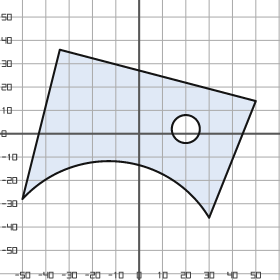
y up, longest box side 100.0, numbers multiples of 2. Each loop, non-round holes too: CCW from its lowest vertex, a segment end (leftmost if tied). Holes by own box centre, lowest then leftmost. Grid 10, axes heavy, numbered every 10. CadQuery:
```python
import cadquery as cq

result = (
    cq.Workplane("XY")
    .moveTo(30.0, -36.0)
    .lineTo(50.0, 14.0)
    .lineTo(-34.0, 36.0)
    .lineTo(-50.0, -28.0)
    .threePointArc((-8.0, -12.0), (30.0, -36.0))
    .close()
    .moveTo(20.0, 2.0)
    .circle(6.0)
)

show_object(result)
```